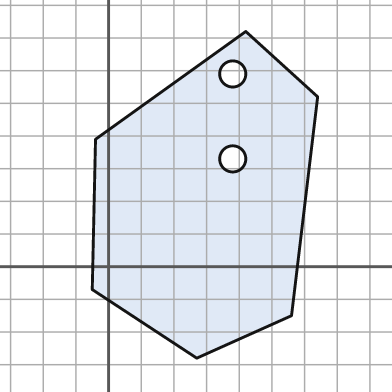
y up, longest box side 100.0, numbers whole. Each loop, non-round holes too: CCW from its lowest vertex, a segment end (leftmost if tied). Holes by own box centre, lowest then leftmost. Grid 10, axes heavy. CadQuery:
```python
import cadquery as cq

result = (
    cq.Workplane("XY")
    .moveTo(27.0, -28.0)
    .lineTo(56.0, -15.0)
    .lineTo(64.0, 52.0)
    .lineTo(42.0, 72.0)
    .lineTo(-4.0, 39.0)
    .lineTo(-5.0, -7.0)
    .close()
    .moveTo(38.0, 33.0)
    .circle(4.0)
    .moveTo(38.0, 59.0)
    .circle(4.0)
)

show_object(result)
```